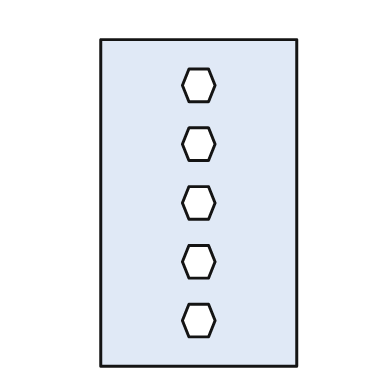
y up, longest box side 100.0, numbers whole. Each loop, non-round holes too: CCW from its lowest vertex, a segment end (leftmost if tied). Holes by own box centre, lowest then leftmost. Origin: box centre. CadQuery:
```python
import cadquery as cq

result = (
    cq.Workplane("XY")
    .moveTo(-30.0, -50.0)
    .lineTo(30.0, -50.0)
    .lineTo(30.0, 50.0)
    .lineTo(-30.0, 50.0)
    .close()
    .moveTo(-3.0, -41.0)
    .lineTo(3.0, -41.0)
    .lineTo(5.0, -36.0)
    .lineTo(3.0, -31.0)
    .lineTo(-3.0, -31.0)
    .lineTo(-5.0, -36.0)
    .close()
    .moveTo(-3.0, -23.0)
    .lineTo(3.0, -23.0)
    .lineTo(5.0, -18.0)
    .lineTo(3.0, -13.0)
    .lineTo(-3.0, -13.0)
    .lineTo(-5.0, -18.0)
    .close()
    .moveTo(-3.0, -5.0)
    .lineTo(3.0, -5.0)
    .lineTo(5.0, 0.0)
    .lineTo(3.0, 5.0)
    .lineTo(-3.0, 5.0)
    .lineTo(-5.0, 0.0)
    .close()
    .moveTo(-3.0, 13.0)
    .lineTo(3.0, 13.0)
    .lineTo(5.0, 18.0)
    .lineTo(3.0, 23.0)
    .lineTo(-3.0, 23.0)
    .lineTo(-5.0, 18.0)
    .close()
    .moveTo(-3.0, 31.0)
    .lineTo(3.0, 31.0)
    .lineTo(5.0, 36.0)
    .lineTo(3.0, 41.0)
    .lineTo(-3.0, 41.0)
    .lineTo(-5.0, 36.0)
    .close()
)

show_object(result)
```